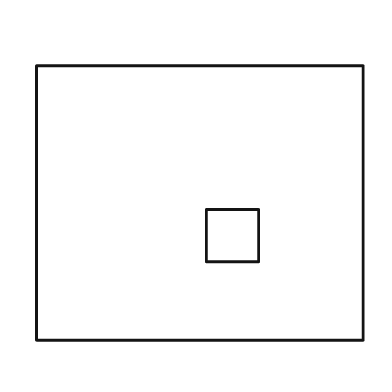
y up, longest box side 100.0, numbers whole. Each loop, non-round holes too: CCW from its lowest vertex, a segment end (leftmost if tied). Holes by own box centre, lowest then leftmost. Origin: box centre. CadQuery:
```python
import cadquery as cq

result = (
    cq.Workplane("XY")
    .moveTo(-50.0, -42.0)
    .lineTo(50.0, -42.0)
    .lineTo(50.0, 42.0)
    .lineTo(-50.0, 42.0)
    .close()
    .moveTo(2.0, -18.0)
    .lineTo(18.0, -18.0)
    .lineTo(18.0, -2.0)
    .lineTo(2.0, -2.0)
    .close()
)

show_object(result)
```